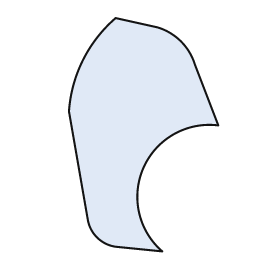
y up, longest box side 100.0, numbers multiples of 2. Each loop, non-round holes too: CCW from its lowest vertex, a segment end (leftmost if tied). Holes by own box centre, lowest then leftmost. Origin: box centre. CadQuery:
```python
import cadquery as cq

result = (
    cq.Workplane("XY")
    .moveTo(8.0, -50.0)
    .threePointArc((0.0, -14.0), (32.0, 4.0))
    .lineTo(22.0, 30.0)
    .threePointArc((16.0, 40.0), (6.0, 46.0))
    .lineTo(-12.0, 50.0)
    .threePointArc((-26.0, 32.0), (-32.0, 10.0))
    .lineTo(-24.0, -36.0)
    .threePointArc((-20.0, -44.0), (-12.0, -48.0))
    .close()
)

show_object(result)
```